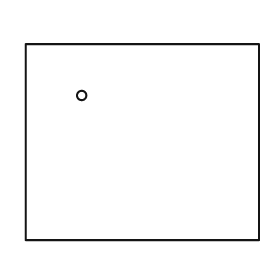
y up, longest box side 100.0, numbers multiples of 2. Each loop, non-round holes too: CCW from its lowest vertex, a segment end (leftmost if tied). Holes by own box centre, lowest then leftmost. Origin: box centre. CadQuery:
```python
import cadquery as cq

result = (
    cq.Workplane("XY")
    .moveTo(-50.0, -42.0)
    .lineTo(50.0, -42.0)
    .lineTo(50.0, 42.0)
    .lineTo(-50.0, 42.0)
    .close()
    .moveTo(-26.0, 20.0)
    .circle(2.0)
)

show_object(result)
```